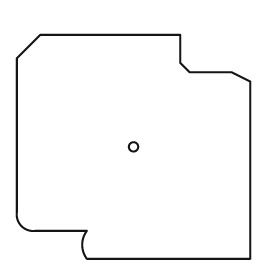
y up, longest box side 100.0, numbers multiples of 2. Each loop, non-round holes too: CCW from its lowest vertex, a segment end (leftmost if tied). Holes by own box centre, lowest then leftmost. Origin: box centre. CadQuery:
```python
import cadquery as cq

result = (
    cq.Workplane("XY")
    .moveTo(-20.0, -48.0)
    .lineTo(50.0, -48.0)
    .lineTo(50.0, 28.0)
    .lineTo(42.0, 32.0)
    .lineTo(24.0, 32.0)
    .lineTo(20.0, 36.0)
    .lineTo(20.0, 48.0)
    .lineTo(-40.0, 48.0)
    .lineTo(-50.0, 38.0)
    .lineTo(-50.0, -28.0)
    .threePointArc((-48.0, -34.0), (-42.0, -36.0))
    .lineTo(-20.0, -36.0)
    .threePointArc((-22.0, -42.0), (-20.0, -48.0))
    .close()
    .moveTo(0.0, 0.0)
    .circle(2.0)
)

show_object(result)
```